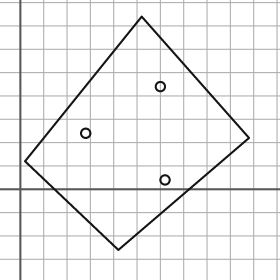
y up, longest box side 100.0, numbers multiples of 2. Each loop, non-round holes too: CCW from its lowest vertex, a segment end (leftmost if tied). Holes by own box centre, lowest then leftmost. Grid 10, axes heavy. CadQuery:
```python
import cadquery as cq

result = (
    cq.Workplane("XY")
    .moveTo(42.0, -26.0)
    .lineTo(98.0, 22.0)
    .lineTo(52.0, 74.0)
    .lineTo(2.0, 12.0)
    .close()
    .moveTo(62.0, 4.0)
    .circle(2.0)
    .moveTo(28.0, 24.0)
    .circle(2.0)
    .moveTo(60.0, 44.0)
    .circle(2.0)
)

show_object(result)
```